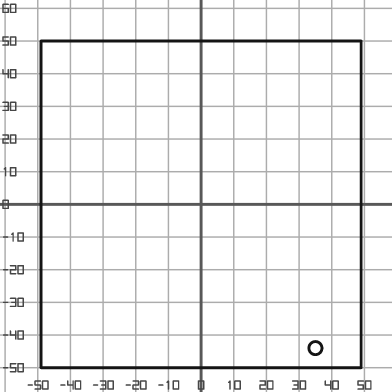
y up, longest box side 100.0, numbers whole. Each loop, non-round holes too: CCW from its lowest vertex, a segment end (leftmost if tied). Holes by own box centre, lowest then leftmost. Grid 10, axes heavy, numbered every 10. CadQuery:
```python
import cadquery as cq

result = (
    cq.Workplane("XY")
    .moveTo(-49.0, -50.0)
    .lineTo(49.0, -50.0)
    .lineTo(49.0, 50.0)
    .lineTo(-49.0, 50.0)
    .close()
    .moveTo(35.0, -44.0)
    .circle(2.0)
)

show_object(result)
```